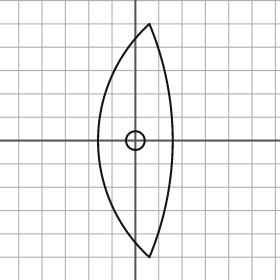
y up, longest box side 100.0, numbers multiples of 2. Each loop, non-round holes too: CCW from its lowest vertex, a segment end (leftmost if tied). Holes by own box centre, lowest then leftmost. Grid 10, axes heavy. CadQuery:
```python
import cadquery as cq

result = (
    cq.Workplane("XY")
    .moveTo(6.0, -50.0)
    .threePointArc((16.0, 0.0), (6.0, 50.0))
    .threePointArc((-16.0, 0.0), (6.0, -50.0))
    .close()
    .moveTo(0.0, 0.0)
    .circle(4.0)
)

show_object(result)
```